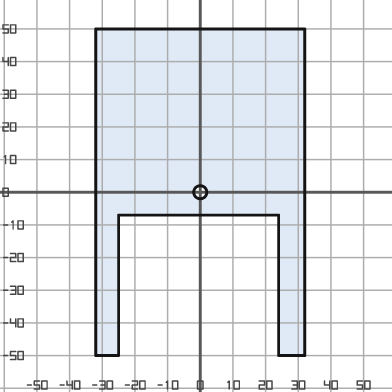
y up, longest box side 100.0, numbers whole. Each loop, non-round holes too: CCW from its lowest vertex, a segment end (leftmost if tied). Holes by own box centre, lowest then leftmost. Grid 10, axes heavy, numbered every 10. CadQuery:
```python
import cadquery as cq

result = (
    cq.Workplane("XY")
    .moveTo(-32.0, -50.0)
    .lineTo(-25.0, -50.0)
    .lineTo(-25.0, -7.0)
    .lineTo(24.0, -7.0)
    .lineTo(24.0, -50.0)
    .lineTo(32.0, -50.0)
    .lineTo(32.0, 50.0)
    .lineTo(-32.0, 50.0)
    .close()
    .moveTo(0.0, 0.0)
    .circle(2.0)
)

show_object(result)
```